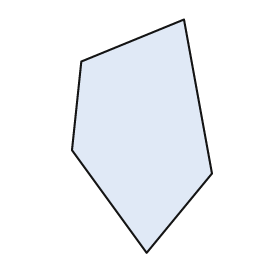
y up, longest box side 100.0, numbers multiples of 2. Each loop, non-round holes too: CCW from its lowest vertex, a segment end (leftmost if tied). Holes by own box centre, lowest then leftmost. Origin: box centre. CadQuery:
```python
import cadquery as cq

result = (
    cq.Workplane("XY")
    .moveTo(2.0, -50.0)
    .lineTo(30.0, -16.0)
    .lineTo(18.0, 50.0)
    .lineTo(-26.0, 32.0)
    .lineTo(-30.0, -6.0)
    .close()
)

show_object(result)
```